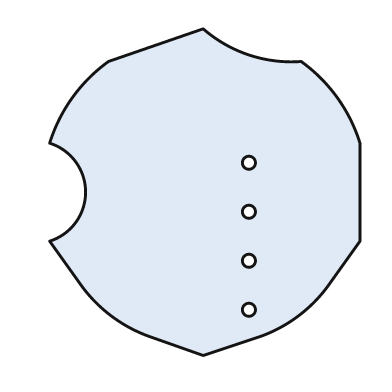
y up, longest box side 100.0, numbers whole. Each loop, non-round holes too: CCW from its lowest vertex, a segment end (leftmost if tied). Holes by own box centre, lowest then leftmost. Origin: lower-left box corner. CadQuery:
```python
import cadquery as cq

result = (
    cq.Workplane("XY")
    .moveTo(47.0, 0.0)
    .lineTo(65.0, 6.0)
    .threePointArc((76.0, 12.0), (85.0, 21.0))
    .lineTo(95.0, 35.0)
    .lineTo(95.0, 65.0)
    .threePointArc((88.0, 79.0), (77.0, 90.0))
    .threePointArc((61.0, 92.0), (47.0, 100.0))
    .lineTo(18.0, 90.0)
    .threePointArc((7.0, 79.0), (0.0, 65.0))
    .threePointArc((11.0, 50.0), (0.0, 35.0))
    .lineTo(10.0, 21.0)
    .threePointArc((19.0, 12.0), (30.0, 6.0))
    .close()
    .moveTo(61.0, 14.0)
    .circle(2.0)
    .moveTo(61.0, 29.0)
    .circle(2.0)
    .moveTo(61.0, 44.0)
    .circle(2.0)
    .moveTo(61.0, 59.0)
    .circle(2.0)
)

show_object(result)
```